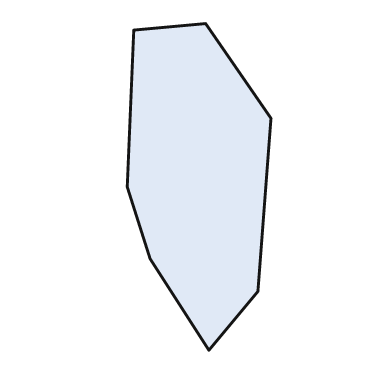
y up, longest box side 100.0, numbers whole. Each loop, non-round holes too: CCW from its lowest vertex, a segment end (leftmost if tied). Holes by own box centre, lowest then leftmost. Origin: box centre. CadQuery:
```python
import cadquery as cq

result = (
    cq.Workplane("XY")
    .moveTo(3.0, -50.0)
    .lineTo(18.0, -32.0)
    .lineTo(22.0, 21.0)
    .lineTo(2.0, 50.0)
    .lineTo(-20.0, 48.0)
    .lineTo(-22.0, 0.0)
    .lineTo(-15.0, -22.0)
    .close()
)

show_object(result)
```